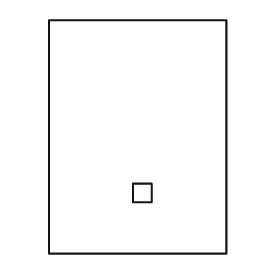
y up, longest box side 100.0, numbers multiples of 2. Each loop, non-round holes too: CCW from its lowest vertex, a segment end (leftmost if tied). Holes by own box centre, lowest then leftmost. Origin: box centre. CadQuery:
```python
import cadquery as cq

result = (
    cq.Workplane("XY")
    .moveTo(-38.0, -50.0)
    .lineTo(38.0, -50.0)
    .lineTo(38.0, 50.0)
    .lineTo(-38.0, 50.0)
    .close()
    .moveTo(-2.0, -28.0)
    .lineTo(6.0, -28.0)
    .lineTo(6.0, -20.0)
    .lineTo(-2.0, -20.0)
    .close()
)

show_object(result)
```